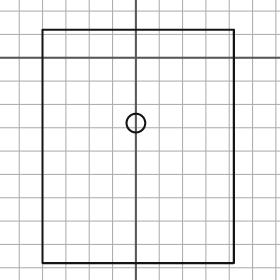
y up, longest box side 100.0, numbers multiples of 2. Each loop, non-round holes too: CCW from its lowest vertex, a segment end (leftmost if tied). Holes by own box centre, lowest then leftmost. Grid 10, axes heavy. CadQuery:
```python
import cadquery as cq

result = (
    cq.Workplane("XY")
    .moveTo(-40.0, -88.0)
    .lineTo(42.0, -88.0)
    .lineTo(42.0, 12.0)
    .lineTo(-40.0, 12.0)
    .close()
    .moveTo(0.0, -28.0)
    .circle(4.0)
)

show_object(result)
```